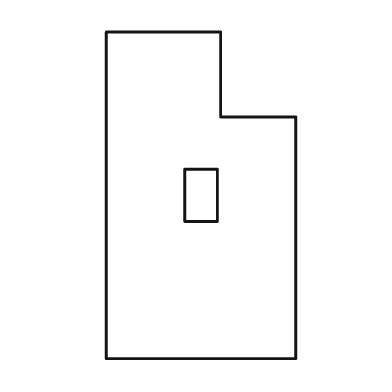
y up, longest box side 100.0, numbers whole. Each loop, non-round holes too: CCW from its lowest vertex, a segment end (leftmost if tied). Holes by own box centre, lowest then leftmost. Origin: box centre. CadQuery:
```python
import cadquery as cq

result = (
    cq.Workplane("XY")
    .moveTo(-29.0, -50.0)
    .lineTo(29.0, -50.0)
    .lineTo(29.0, 24.0)
    .lineTo(6.0, 24.0)
    .lineTo(6.0, 50.0)
    .lineTo(-29.0, 50.0)
    .close()
    .moveTo(-5.0, -8.0)
    .lineTo(5.0, -8.0)
    .lineTo(5.0, 8.0)
    .lineTo(-5.0, 8.0)
    .close()
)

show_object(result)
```